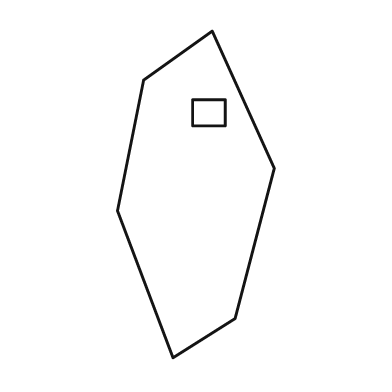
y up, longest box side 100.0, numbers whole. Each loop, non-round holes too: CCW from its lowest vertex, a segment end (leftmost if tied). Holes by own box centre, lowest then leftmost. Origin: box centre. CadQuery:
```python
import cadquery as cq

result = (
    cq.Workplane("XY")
    .moveTo(-7.0, -50.0)
    .lineTo(12.0, -38.0)
    .lineTo(24.0, 8.0)
    .lineTo(5.0, 50.0)
    .lineTo(-16.0, 35.0)
    .lineTo(-24.0, -5.0)
    .close()
    .moveTo(-1.0, 21.0)
    .lineTo(9.0, 21.0)
    .lineTo(9.0, 29.0)
    .lineTo(-1.0, 29.0)
    .close()
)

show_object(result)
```